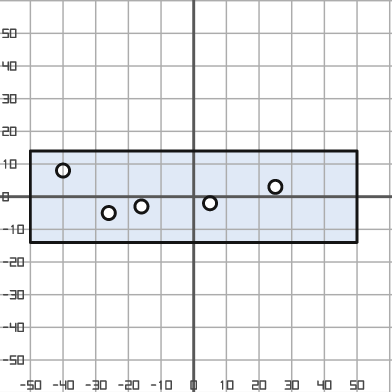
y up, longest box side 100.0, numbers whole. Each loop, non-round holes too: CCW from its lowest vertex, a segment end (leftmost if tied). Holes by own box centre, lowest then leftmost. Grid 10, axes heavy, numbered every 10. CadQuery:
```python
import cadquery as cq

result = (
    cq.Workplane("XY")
    .moveTo(-50.0, -14.0)
    .lineTo(50.0, -14.0)
    .lineTo(50.0, 14.0)
    .lineTo(-50.0, 14.0)
    .close()
    .moveTo(-26.0, -5.0)
    .circle(2.0)
    .moveTo(-16.0, -3.0)
    .circle(2.0)
    .moveTo(5.0, -2.0)
    .circle(2.0)
    .moveTo(25.0, 3.0)
    .circle(2.0)
    .moveTo(-40.0, 8.0)
    .circle(2.0)
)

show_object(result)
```